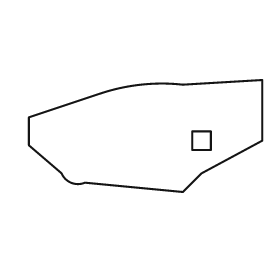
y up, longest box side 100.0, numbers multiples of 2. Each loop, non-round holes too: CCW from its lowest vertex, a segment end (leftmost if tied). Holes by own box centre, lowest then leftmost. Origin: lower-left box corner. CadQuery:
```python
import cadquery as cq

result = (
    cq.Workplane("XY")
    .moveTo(66.0, 0.0)
    .lineTo(74.0, 8.0)
    .lineTo(100.0, 22.0)
    .lineTo(100.0, 48.0)
    .lineTo(66.0, 46.0)
    .threePointArc((48.0, 46.0), (30.0, 42.0))
    .lineTo(0.0, 32.0)
    .lineTo(0.0, 20.0)
    .lineTo(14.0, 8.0)
    .threePointArc((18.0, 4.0), (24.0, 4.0))
    .close()
    .moveTo(70.0, 18.0)
    .lineTo(78.0, 18.0)
    .lineTo(78.0, 26.0)
    .lineTo(70.0, 26.0)
    .close()
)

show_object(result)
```